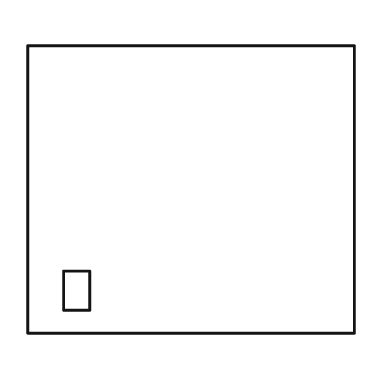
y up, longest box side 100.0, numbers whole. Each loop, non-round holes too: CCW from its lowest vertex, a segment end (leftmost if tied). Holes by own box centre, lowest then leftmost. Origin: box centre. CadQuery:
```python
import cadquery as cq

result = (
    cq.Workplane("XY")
    .moveTo(-50.0, -44.0)
    .lineTo(50.0, -44.0)
    .lineTo(50.0, 44.0)
    .lineTo(-50.0, 44.0)
    .close()
    .moveTo(-39.0, -37.0)
    .lineTo(-31.0, -37.0)
    .lineTo(-31.0, -25.0)
    .lineTo(-39.0, -25.0)
    .close()
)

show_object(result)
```